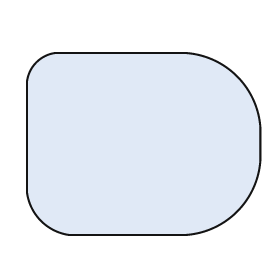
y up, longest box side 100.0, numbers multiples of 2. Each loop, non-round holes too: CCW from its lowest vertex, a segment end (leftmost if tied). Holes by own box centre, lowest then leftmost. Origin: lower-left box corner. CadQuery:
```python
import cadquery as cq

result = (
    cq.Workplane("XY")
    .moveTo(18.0, 0.0)
    .lineTo(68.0, 0.0)
    .threePointArc((90.0, 10.0), (100.0, 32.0))
    .lineTo(100.0, 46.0)
    .threePointArc((90.0, 68.0), (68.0, 78.0))
    .lineTo(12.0, 78.0)
    .threePointArc((4.0, 74.0), (0.0, 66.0))
    .lineTo(0.0, 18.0)
    .threePointArc((6.0, 6.0), (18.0, 0.0))
    .close()
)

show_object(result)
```